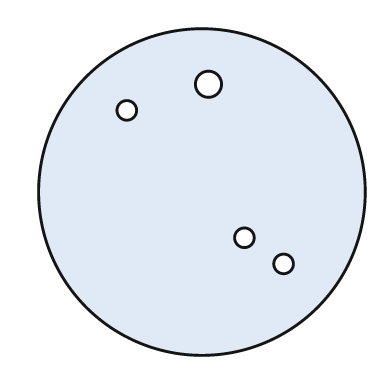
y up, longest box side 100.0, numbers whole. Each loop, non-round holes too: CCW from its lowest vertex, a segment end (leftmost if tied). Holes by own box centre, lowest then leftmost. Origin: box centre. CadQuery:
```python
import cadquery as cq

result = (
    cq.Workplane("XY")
    .moveTo(0.0, 0.0)
    .circle(50.0)
    .moveTo(25.0, -22.0)
    .circle(3.0)
    .moveTo(13.0, -14.0)
    .circle(3.0)
    .moveTo(-23.0, 25.0)
    .circle(3.0)
    .moveTo(2.0, 33.0)
    .circle(4.0)
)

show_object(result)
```